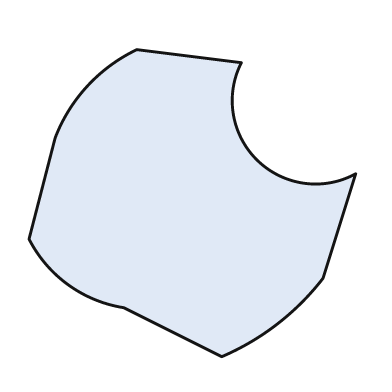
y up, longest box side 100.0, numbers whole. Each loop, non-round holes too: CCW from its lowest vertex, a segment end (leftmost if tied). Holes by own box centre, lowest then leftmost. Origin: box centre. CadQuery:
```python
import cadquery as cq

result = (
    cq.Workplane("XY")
    .moveTo(9.0, -47.0)
    .threePointArc((26.0, -37.0), (40.0, -23.0))
    .lineTo(50.0, 9.0)
    .threePointArc((20.0, 13.0), (15.0, 43.0))
    .lineTo(-17.0, 47.0)
    .threePointArc((-32.0, 36.0), (-42.0, 20.0))
    .lineTo(-50.0, -11.0)
    .threePointArc((-38.0, -25.0), (-21.0, -32.0))
    .close()
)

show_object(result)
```